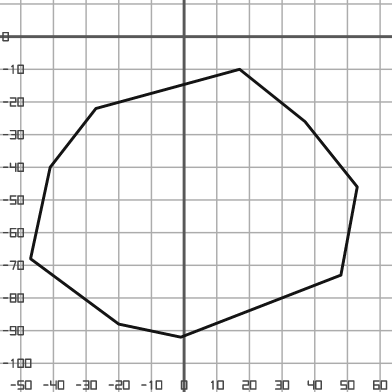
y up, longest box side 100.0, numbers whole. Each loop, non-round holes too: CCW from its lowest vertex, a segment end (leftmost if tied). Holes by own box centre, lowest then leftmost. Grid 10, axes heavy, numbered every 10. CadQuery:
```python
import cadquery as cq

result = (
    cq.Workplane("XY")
    .moveTo(-1.0, -92.0)
    .lineTo(48.0, -73.0)
    .lineTo(53.0, -46.0)
    .lineTo(37.0, -26.0)
    .lineTo(17.0, -10.0)
    .lineTo(-27.0, -22.0)
    .lineTo(-41.0, -40.0)
    .lineTo(-47.0, -68.0)
    .lineTo(-20.0, -88.0)
    .close()
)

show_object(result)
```